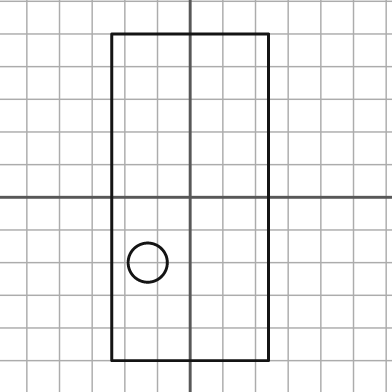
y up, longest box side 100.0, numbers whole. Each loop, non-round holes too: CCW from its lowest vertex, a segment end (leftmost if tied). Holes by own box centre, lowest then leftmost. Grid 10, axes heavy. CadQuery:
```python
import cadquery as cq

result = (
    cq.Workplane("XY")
    .moveTo(-24.0, -50.0)
    .lineTo(24.0, -50.0)
    .lineTo(24.0, 50.0)
    .lineTo(-24.0, 50.0)
    .close()
    .moveTo(-13.0, -20.0)
    .circle(6.0)
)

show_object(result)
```